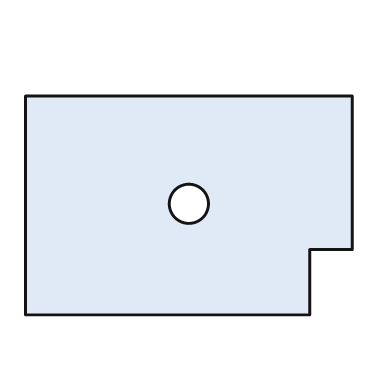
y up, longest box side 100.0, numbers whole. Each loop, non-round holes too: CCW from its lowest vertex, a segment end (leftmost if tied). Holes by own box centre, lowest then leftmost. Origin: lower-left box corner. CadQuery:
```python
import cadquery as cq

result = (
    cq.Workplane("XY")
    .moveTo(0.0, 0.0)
    .lineTo(87.0, 0.0)
    .lineTo(87.0, 20.0)
    .lineTo(100.0, 20.0)
    .lineTo(100.0, 67.0)
    .lineTo(0.0, 67.0)
    .close()
    .moveTo(50.0, 34.0)
    .circle(6.0)
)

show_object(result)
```